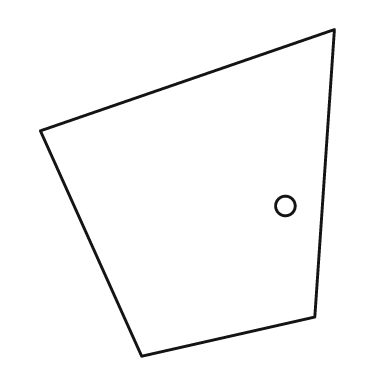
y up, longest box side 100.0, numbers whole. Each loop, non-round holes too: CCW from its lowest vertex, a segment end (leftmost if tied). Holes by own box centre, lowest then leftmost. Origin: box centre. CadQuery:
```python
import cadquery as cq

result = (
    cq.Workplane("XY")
    .moveTo(-14.0, -50.0)
    .lineTo(39.0, -38.0)
    .lineTo(45.0, 50.0)
    .lineTo(-45.0, 19.0)
    .close()
    .moveTo(30.0, -4.0)
    .circle(3.0)
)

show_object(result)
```